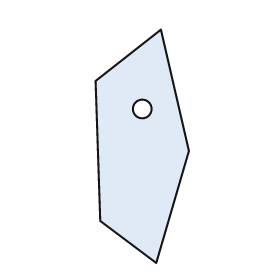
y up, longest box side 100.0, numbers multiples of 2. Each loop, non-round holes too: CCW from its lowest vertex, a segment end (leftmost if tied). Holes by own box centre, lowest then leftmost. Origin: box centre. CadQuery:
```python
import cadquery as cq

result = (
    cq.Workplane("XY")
    .moveTo(6.0, -50.0)
    .lineTo(20.0, -2.0)
    .lineTo(8.0, 50.0)
    .lineTo(-20.0, 28.0)
    .lineTo(-18.0, -32.0)
    .close()
    .moveTo(0.0, 16.0)
    .circle(4.0)
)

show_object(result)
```